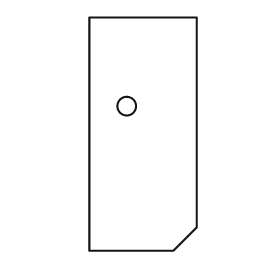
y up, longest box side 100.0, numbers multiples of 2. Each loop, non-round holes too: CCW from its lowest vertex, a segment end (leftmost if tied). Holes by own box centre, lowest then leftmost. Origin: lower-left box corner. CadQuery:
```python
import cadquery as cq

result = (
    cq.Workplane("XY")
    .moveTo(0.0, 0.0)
    .lineTo(36.0, 0.0)
    .lineTo(46.0, 10.0)
    .lineTo(46.0, 100.0)
    .lineTo(0.0, 100.0)
    .close()
    .moveTo(16.0, 62.0)
    .circle(4.0)
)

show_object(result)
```